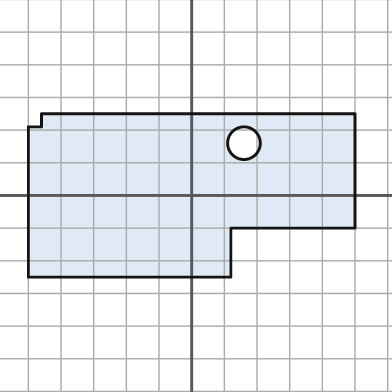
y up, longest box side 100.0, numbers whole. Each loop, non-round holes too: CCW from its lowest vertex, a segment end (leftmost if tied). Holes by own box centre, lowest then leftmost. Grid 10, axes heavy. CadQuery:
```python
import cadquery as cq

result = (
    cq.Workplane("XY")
    .moveTo(-50.0, -25.0)
    .lineTo(12.0, -25.0)
    .lineTo(12.0, -10.0)
    .lineTo(50.0, -10.0)
    .lineTo(50.0, 25.0)
    .lineTo(-46.0, 25.0)
    .lineTo(-46.0, 21.0)
    .lineTo(-50.0, 21.0)
    .close()
    .moveTo(16.0, 16.0)
    .circle(5.0)
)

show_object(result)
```